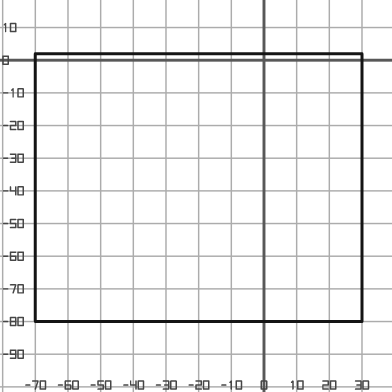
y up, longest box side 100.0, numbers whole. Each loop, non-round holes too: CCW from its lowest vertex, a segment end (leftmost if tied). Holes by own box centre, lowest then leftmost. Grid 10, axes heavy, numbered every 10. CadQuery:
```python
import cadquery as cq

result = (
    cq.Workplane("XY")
    .moveTo(-70.0, -80.0)
    .lineTo(30.0, -80.0)
    .lineTo(30.0, 2.0)
    .lineTo(-70.0, 2.0)
    .close()
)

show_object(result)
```